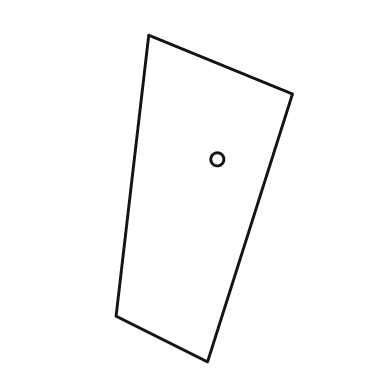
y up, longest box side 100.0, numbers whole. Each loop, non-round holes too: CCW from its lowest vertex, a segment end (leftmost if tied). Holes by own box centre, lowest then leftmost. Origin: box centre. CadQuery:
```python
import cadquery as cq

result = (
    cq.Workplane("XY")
    .moveTo(1.0, -50.0)
    .lineTo(27.0, 32.0)
    .lineTo(-17.0, 50.0)
    .lineTo(-27.0, -36.0)
    .close()
    .moveTo(4.0, 12.0)
    .circle(2.0)
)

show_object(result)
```